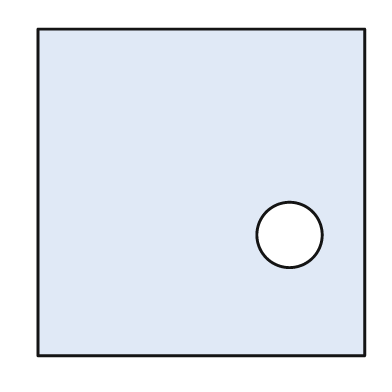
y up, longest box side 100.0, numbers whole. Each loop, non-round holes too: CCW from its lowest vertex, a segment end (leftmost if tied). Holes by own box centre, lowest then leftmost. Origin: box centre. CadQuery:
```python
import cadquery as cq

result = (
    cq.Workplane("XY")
    .moveTo(-50.0, -50.0)
    .lineTo(50.0, -50.0)
    .lineTo(50.0, 50.0)
    .lineTo(-50.0, 50.0)
    .close()
    .moveTo(27.0, -13.0)
    .circle(10.0)
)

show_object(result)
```